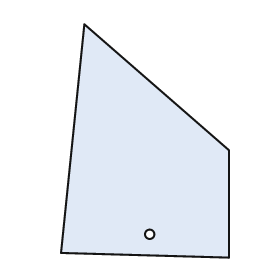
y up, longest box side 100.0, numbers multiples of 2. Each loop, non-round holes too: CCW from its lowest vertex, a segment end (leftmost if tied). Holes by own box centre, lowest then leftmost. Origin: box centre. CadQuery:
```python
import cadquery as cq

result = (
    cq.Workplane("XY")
    .moveTo(36.0, -50.0)
    .lineTo(36.0, -4.0)
    .lineTo(-26.0, 50.0)
    .lineTo(-36.0, -48.0)
    .close()
    .moveTo(2.0, -40.0)
    .circle(2.0)
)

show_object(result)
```